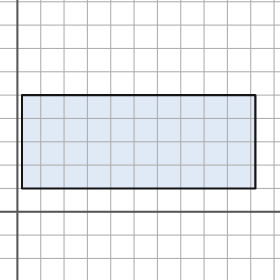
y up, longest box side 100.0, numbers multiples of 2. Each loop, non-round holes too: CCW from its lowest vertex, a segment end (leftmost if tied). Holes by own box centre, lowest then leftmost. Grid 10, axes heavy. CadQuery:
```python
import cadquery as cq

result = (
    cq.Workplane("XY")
    .moveTo(2.0, 10.0)
    .lineTo(102.0, 10.0)
    .lineTo(102.0, 50.0)
    .lineTo(2.0, 50.0)
    .close()
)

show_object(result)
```